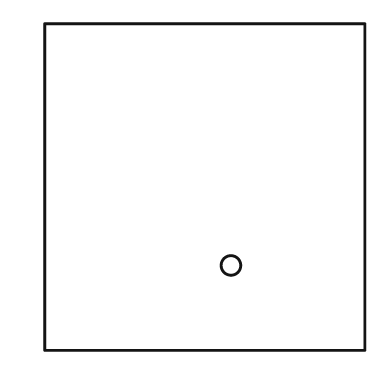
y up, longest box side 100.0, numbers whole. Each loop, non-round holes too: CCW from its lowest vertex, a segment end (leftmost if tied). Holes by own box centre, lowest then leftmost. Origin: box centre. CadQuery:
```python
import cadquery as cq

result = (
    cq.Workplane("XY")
    .moveTo(-49.0, -50.0)
    .lineTo(49.0, -50.0)
    .lineTo(49.0, 50.0)
    .lineTo(-49.0, 50.0)
    .close()
    .moveTo(8.0, -24.0)
    .circle(3.0)
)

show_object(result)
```